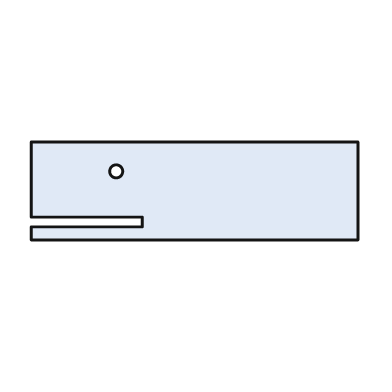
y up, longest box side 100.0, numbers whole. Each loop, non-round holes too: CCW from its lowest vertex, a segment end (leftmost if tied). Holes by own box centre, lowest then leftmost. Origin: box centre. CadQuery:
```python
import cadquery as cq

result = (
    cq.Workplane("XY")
    .moveTo(-50.0, -15.0)
    .lineTo(50.0, -15.0)
    .lineTo(50.0, 15.0)
    .lineTo(-50.0, 15.0)
    .lineTo(-50.0, -8.0)
    .lineTo(-16.0, -8.0)
    .lineTo(-16.0, -11.0)
    .lineTo(-50.0, -11.0)
    .close()
    .moveTo(-24.0, 6.0)
    .circle(2.0)
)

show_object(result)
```